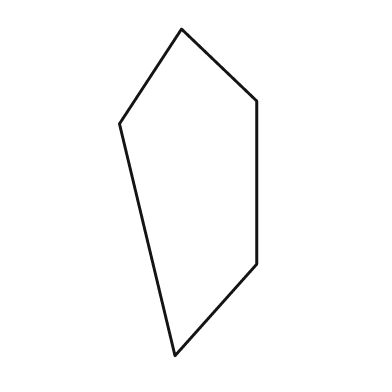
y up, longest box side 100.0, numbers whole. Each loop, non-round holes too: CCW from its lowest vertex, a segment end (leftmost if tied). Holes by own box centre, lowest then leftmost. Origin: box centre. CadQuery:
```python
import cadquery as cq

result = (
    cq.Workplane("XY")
    .moveTo(-4.0, -50.0)
    .lineTo(21.0, -22.0)
    .lineTo(21.0, 28.0)
    .lineTo(-2.0, 50.0)
    .lineTo(-21.0, 21.0)
    .close()
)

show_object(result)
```